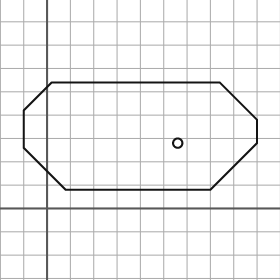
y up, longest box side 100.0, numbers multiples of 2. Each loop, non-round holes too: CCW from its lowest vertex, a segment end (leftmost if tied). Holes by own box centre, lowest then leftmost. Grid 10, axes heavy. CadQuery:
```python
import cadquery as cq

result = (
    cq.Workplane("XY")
    .moveTo(8.0, 8.0)
    .lineTo(70.0, 8.0)
    .lineTo(90.0, 28.0)
    .lineTo(90.0, 38.0)
    .lineTo(74.0, 54.0)
    .lineTo(2.0, 54.0)
    .lineTo(-10.0, 42.0)
    .lineTo(-10.0, 26.0)
    .close()
    .moveTo(56.0, 28.0)
    .circle(2.0)
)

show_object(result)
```